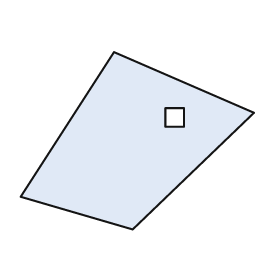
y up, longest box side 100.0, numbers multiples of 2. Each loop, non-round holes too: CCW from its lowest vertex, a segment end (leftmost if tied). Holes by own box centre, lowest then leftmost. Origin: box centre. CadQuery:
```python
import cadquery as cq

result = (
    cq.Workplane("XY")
    .moveTo(-2.0, -38.0)
    .lineTo(50.0, 12.0)
    .lineTo(-10.0, 38.0)
    .lineTo(-50.0, -24.0)
    .close()
    .moveTo(12.0, 6.0)
    .lineTo(20.0, 6.0)
    .lineTo(20.0, 14.0)
    .lineTo(12.0, 14.0)
    .close()
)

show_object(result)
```